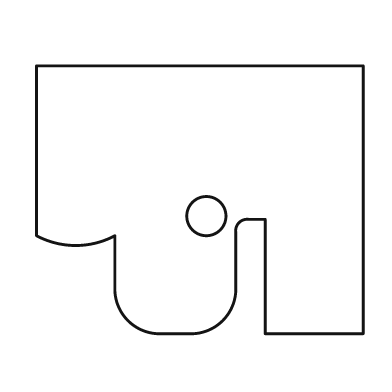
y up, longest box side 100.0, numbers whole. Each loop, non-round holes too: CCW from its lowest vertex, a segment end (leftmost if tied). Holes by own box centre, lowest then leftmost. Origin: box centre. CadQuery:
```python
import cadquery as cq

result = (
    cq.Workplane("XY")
    .moveTo(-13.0, -41.0)
    .lineTo(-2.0, -41.0)
    .threePointArc((7.0, -37.0), (11.0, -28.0))
    .lineTo(11.0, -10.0)
    .threePointArc((12.0, -7.0), (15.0, -6.0))
    .lineTo(20.0, -6.0)
    .lineTo(20.0, -41.0)
    .lineTo(50.0, -41.0)
    .lineTo(50.0, 41.0)
    .lineTo(-50.0, 41.0)
    .lineTo(-50.0, -11.0)
    .threePointArc((-38.0, -14.0), (-26.0, -11.0))
    .lineTo(-26.0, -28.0)
    .threePointArc((-22.0, -37.0), (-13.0, -41.0))
    .close()
    .moveTo(2.0, -5.0)
    .circle(6.0)
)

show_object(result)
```